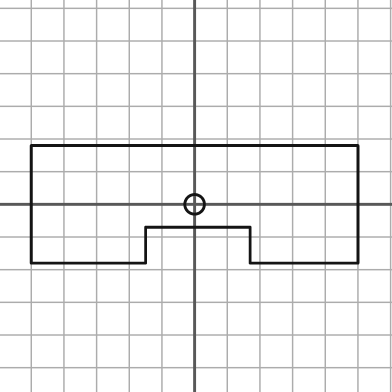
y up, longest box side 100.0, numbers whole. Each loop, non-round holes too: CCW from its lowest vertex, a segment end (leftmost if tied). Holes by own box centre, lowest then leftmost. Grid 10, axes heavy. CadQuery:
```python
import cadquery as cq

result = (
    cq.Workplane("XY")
    .moveTo(-50.0, -18.0)
    .lineTo(-15.0, -18.0)
    .lineTo(-15.0, -7.0)
    .lineTo(17.0, -7.0)
    .lineTo(17.0, -18.0)
    .lineTo(50.0, -18.0)
    .lineTo(50.0, 18.0)
    .lineTo(-50.0, 18.0)
    .close()
    .moveTo(0.0, 0.0)
    .circle(3.0)
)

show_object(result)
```